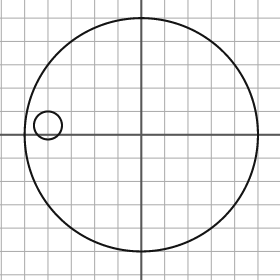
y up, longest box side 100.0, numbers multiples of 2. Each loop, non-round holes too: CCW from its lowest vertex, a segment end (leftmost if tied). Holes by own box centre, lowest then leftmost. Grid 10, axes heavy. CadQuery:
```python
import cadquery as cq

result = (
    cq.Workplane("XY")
    .moveTo(0.0, 0.0)
    .circle(50.0)
    .moveTo(-40.0, 4.0)
    .circle(6.0)
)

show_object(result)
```